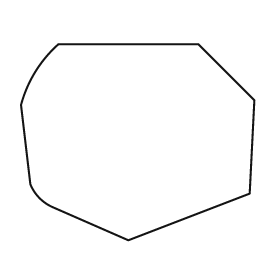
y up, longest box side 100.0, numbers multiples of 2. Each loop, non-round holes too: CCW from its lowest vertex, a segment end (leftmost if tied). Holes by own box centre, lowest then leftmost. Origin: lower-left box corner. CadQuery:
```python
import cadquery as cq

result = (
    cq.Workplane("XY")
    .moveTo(46.0, 0.0)
    .lineTo(98.0, 20.0)
    .lineTo(100.0, 60.0)
    .lineTo(76.0, 84.0)
    .lineTo(16.0, 84.0)
    .threePointArc((6.0, 72.0), (0.0, 58.0))
    .lineTo(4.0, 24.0)
    .threePointArc((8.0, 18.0), (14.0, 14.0))
    .close()
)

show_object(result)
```